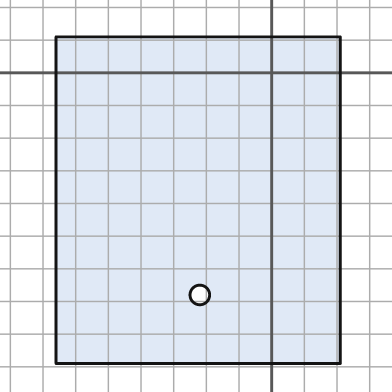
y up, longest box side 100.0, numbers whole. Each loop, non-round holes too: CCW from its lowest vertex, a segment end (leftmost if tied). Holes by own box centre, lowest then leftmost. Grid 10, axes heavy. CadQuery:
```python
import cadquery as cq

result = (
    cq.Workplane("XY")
    .moveTo(-66.0, -89.0)
    .lineTo(21.0, -89.0)
    .lineTo(21.0, 11.0)
    .lineTo(-66.0, 11.0)
    .close()
    .moveTo(-22.0, -68.0)
    .circle(3.0)
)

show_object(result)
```